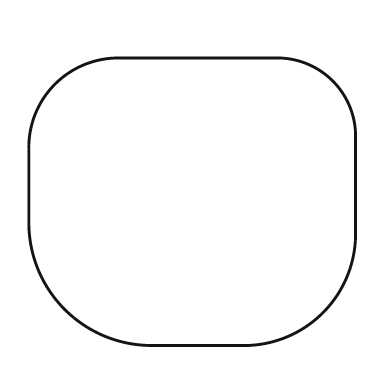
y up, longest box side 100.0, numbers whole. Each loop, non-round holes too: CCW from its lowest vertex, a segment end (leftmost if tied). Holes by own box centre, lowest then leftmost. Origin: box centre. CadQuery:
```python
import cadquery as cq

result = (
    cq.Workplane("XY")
    .moveTo(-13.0, -44.0)
    .lineTo(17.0, -44.0)
    .threePointArc((40.0, -34.0), (50.0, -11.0))
    .lineTo(50.0, 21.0)
    .threePointArc((43.0, 37.0), (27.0, 44.0))
    .lineTo(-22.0, 44.0)
    .threePointArc((-42.0, 36.0), (-50.0, 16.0))
    .lineTo(-50.0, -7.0)
    .threePointArc((-39.0, -33.0), (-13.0, -44.0))
    .close()
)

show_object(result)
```